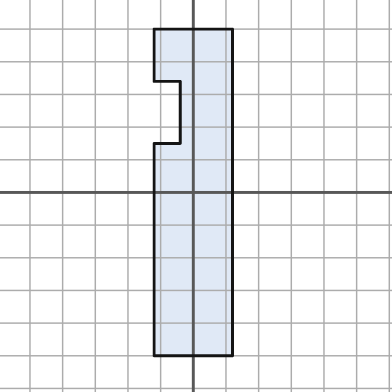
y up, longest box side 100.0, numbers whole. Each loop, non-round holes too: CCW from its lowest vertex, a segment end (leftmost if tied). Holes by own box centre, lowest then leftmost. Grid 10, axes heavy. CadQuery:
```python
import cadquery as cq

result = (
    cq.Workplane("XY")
    .moveTo(-12.0, -50.0)
    .lineTo(12.0, -50.0)
    .lineTo(12.0, 50.0)
    .lineTo(-12.0, 50.0)
    .lineTo(-12.0, 34.0)
    .lineTo(-4.0, 34.0)
    .lineTo(-4.0, 15.0)
    .lineTo(-12.0, 15.0)
    .close()
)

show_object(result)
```